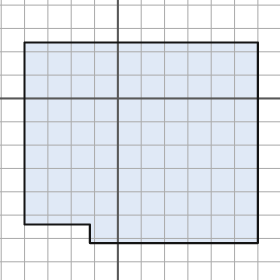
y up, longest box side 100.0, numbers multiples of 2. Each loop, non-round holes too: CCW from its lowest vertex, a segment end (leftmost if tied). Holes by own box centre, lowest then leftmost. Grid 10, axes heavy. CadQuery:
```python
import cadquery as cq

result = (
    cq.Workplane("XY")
    .moveTo(-12.0, -62.0)
    .lineTo(60.0, -62.0)
    .lineTo(60.0, 24.0)
    .lineTo(-40.0, 24.0)
    .lineTo(-40.0, -54.0)
    .lineTo(-12.0, -54.0)
    .close()
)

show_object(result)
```